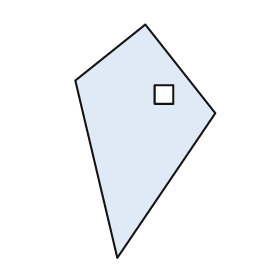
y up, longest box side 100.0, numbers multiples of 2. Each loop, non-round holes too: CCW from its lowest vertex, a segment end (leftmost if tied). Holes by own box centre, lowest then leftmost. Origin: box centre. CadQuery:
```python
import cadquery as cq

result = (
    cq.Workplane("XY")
    .moveTo(-12.0, -50.0)
    .lineTo(30.0, 12.0)
    .lineTo(0.0, 50.0)
    .lineTo(-30.0, 26.0)
    .close()
    .moveTo(4.0, 16.0)
    .lineTo(12.0, 16.0)
    .lineTo(12.0, 24.0)
    .lineTo(4.0, 24.0)
    .close()
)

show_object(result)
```